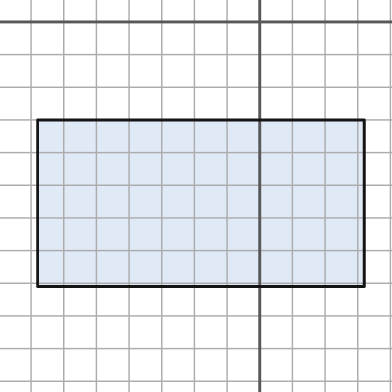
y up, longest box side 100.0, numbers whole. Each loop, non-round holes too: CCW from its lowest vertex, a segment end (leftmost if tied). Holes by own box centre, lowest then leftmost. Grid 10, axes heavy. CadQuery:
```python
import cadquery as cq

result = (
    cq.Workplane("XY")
    .moveTo(-68.0, -81.0)
    .lineTo(32.0, -81.0)
    .lineTo(32.0, -30.0)
    .lineTo(-68.0, -30.0)
    .close()
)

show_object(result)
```